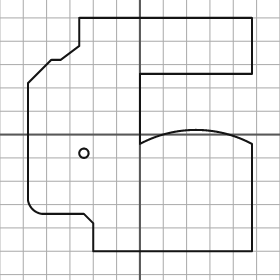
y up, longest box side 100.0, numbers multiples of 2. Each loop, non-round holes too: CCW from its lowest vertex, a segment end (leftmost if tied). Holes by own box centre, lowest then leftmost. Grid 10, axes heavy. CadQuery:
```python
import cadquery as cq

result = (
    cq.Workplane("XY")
    .moveTo(-20.0, -50.0)
    .lineTo(48.0, -50.0)
    .lineTo(48.0, -4.0)
    .threePointArc((24.0, 2.0), (0.0, -4.0))
    .lineTo(0.0, 26.0)
    .lineTo(48.0, 26.0)
    .lineTo(48.0, 50.0)
    .lineTo(-26.0, 50.0)
    .lineTo(-26.0, 38.0)
    .lineTo(-34.0, 32.0)
    .lineTo(-38.0, 32.0)
    .lineTo(-48.0, 22.0)
    .lineTo(-48.0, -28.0)
    .threePointArc((-46.0, -32.0), (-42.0, -34.0))
    .lineTo(-24.0, -34.0)
    .lineTo(-20.0, -38.0)
    .close()
    .moveTo(-24.0, -8.0)
    .circle(2.0)
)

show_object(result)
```